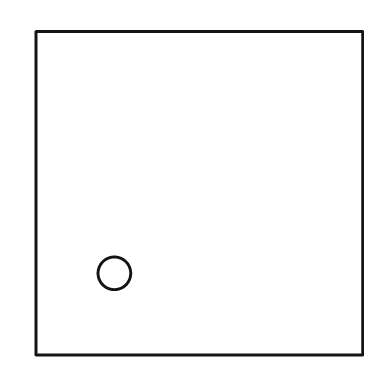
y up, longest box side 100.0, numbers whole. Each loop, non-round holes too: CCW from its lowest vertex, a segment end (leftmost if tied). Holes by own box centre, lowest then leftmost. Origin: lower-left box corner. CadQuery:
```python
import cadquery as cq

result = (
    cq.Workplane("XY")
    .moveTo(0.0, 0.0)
    .lineTo(100.0, 0.0)
    .lineTo(100.0, 99.0)
    .lineTo(0.0, 99.0)
    .close()
    .moveTo(24.0, 25.0)
    .circle(5.0)
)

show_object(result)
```